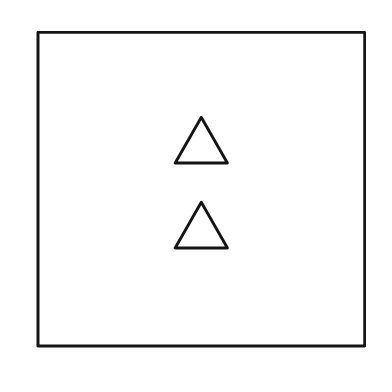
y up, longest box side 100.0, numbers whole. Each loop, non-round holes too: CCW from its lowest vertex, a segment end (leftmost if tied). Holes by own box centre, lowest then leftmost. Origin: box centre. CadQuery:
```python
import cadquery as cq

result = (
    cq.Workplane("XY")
    .moveTo(-50.0, -48.0)
    .lineTo(50.0, -48.0)
    .lineTo(50.0, 48.0)
    .lineTo(-50.0, 48.0)
    .close()
    .moveTo(-8.0, -18.0)
    .lineTo(8.0, -18.0)
    .lineTo(0.0, -4.0)
    .close()
    .moveTo(-8.0, 8.0)
    .lineTo(8.0, 8.0)
    .lineTo(0.0, 22.0)
    .close()
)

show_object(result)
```